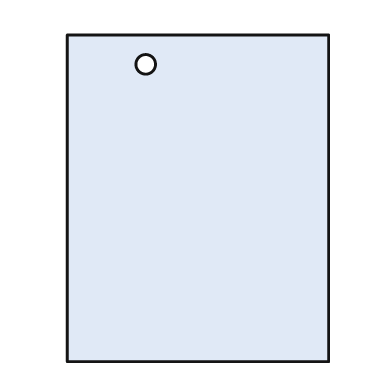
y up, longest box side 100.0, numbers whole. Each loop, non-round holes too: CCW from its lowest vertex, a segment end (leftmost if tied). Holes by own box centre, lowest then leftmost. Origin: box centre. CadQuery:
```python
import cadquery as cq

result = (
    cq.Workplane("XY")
    .moveTo(-40.0, -50.0)
    .lineTo(40.0, -50.0)
    .lineTo(40.0, 50.0)
    .lineTo(-40.0, 50.0)
    .close()
    .moveTo(-16.0, 41.0)
    .circle(3.0)
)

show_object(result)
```